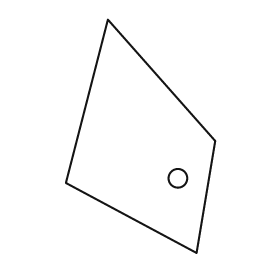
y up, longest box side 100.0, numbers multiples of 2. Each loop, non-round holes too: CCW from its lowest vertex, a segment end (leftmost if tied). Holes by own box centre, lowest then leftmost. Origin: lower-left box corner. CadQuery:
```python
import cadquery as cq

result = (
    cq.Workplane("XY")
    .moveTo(56.0, 0.0)
    .lineTo(64.0, 48.0)
    .lineTo(18.0, 100.0)
    .lineTo(0.0, 30.0)
    .close()
    .moveTo(48.0, 32.0)
    .circle(4.0)
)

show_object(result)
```